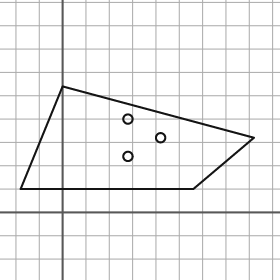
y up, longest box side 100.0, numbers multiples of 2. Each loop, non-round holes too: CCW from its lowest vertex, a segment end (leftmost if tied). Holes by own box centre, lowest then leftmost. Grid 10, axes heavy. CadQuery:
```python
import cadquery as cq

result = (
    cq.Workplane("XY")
    .moveTo(-18.0, 10.0)
    .lineTo(56.0, 10.0)
    .lineTo(82.0, 32.0)
    .lineTo(0.0, 54.0)
    .close()
    .moveTo(28.0, 24.0)
    .circle(2.0)
    .moveTo(42.0, 32.0)
    .circle(2.0)
    .moveTo(28.0, 40.0)
    .circle(2.0)
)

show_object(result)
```